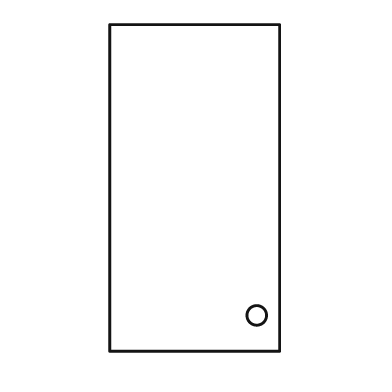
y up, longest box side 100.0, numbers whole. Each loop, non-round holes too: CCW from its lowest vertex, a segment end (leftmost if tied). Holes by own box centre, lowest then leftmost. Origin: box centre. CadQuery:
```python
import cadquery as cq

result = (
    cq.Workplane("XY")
    .moveTo(-26.0, -50.0)
    .lineTo(26.0, -50.0)
    .lineTo(26.0, 50.0)
    .lineTo(-26.0, 50.0)
    .close()
    .moveTo(19.0, -39.0)
    .circle(3.0)
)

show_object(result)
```